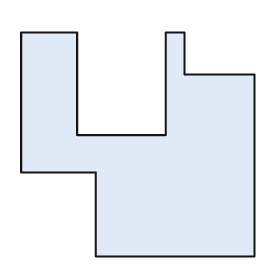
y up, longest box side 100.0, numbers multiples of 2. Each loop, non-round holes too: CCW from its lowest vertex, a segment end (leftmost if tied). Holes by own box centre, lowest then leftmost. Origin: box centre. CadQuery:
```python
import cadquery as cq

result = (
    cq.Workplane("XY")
    .moveTo(-18.0, -48.0)
    .lineTo(50.0, -48.0)
    .lineTo(50.0, 30.0)
    .lineTo(20.0, 30.0)
    .lineTo(20.0, 48.0)
    .lineTo(12.0, 48.0)
    .lineTo(12.0, 4.0)
    .lineTo(-26.0, 4.0)
    .lineTo(-26.0, 48.0)
    .lineTo(-50.0, 48.0)
    .lineTo(-50.0, -12.0)
    .lineTo(-18.0, -12.0)
    .close()
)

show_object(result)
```